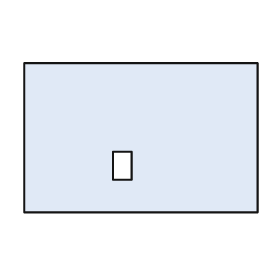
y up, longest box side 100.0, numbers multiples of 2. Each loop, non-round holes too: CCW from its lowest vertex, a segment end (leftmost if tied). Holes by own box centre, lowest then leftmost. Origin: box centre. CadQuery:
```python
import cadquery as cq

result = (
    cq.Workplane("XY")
    .moveTo(-50.0, -32.0)
    .lineTo(50.0, -32.0)
    .lineTo(50.0, 32.0)
    .lineTo(-50.0, 32.0)
    .close()
    .moveTo(-12.0, -18.0)
    .lineTo(-4.0, -18.0)
    .lineTo(-4.0, -6.0)
    .lineTo(-12.0, -6.0)
    .close()
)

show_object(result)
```